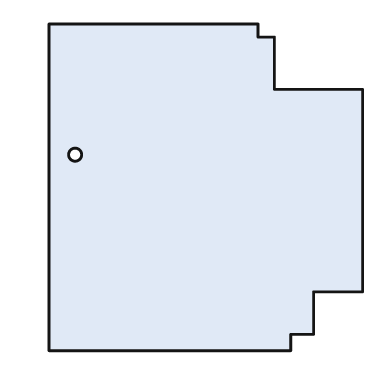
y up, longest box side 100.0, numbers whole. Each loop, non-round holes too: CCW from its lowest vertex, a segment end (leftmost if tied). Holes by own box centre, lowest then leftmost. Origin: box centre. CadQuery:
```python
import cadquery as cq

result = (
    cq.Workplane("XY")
    .moveTo(-48.0, -50.0)
    .lineTo(26.0, -50.0)
    .lineTo(26.0, -45.0)
    .lineTo(33.0, -45.0)
    .lineTo(33.0, -32.0)
    .lineTo(48.0, -32.0)
    .lineTo(48.0, 30.0)
    .lineTo(21.0, 30.0)
    .lineTo(21.0, 46.0)
    .lineTo(16.0, 46.0)
    .lineTo(16.0, 50.0)
    .lineTo(-48.0, 50.0)
    .close()
    .moveTo(-40.0, 10.0)
    .circle(2.0)
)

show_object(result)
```